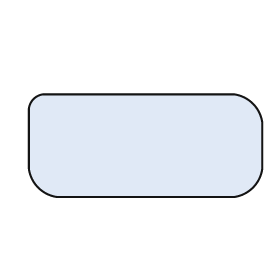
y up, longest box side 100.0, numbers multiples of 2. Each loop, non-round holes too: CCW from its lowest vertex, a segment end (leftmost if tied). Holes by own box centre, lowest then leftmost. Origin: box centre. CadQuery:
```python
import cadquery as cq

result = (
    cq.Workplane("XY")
    .moveTo(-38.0, -22.0)
    .lineTo(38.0, -22.0)
    .threePointArc((46.0, -18.0), (50.0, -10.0))
    .lineTo(50.0, 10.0)
    .threePointArc((46.0, 18.0), (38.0, 22.0))
    .lineTo(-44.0, 22.0)
    .threePointArc((-48.0, 20.0), (-50.0, 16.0))
    .lineTo(-50.0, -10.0)
    .threePointArc((-46.0, -18.0), (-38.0, -22.0))
    .close()
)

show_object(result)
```